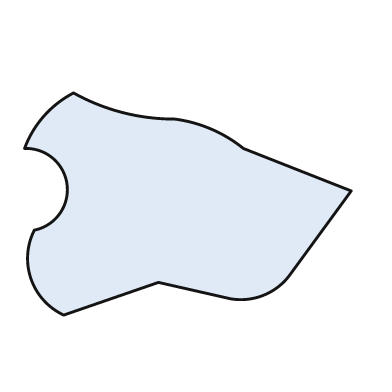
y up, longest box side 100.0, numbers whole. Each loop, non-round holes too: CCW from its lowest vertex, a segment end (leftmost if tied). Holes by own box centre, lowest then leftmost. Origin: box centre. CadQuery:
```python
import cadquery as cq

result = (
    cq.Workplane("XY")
    .moveTo(-38.0, -34.0)
    .lineTo(-9.0, -24.0)
    .lineTo(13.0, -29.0)
    .threePointArc((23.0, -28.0), (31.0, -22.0))
    .lineTo(50.0, 4.0)
    .lineTo(17.0, 17.0)
    .threePointArc((7.0, 23.0), (-4.0, 26.0))
    .threePointArc((-20.0, 28.0), (-35.0, 34.0))
    .threePointArc((-44.0, 27.0), (-50.0, 17.0))
    .threePointArc((-37.0, 6.0), (-47.0, -8.0))
    .threePointArc((-48.0, -23.0), (-38.0, -34.0))
    .close()
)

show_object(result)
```